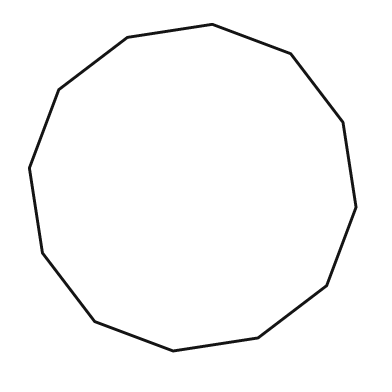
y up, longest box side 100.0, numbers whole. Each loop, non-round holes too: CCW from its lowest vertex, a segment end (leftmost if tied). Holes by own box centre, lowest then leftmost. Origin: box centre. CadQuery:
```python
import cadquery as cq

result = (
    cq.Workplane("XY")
    .moveTo(-6.0, -50.0)
    .lineTo(20.0, -46.0)
    .lineTo(41.0, -30.0)
    .lineTo(50.0, -6.0)
    .lineTo(46.0, 20.0)
    .lineTo(30.0, 41.0)
    .lineTo(6.0, 50.0)
    .lineTo(-20.0, 46.0)
    .lineTo(-41.0, 30.0)
    .lineTo(-50.0, 6.0)
    .lineTo(-46.0, -20.0)
    .lineTo(-30.0, -41.0)
    .close()
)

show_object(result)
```